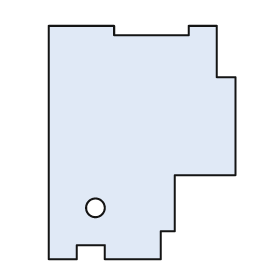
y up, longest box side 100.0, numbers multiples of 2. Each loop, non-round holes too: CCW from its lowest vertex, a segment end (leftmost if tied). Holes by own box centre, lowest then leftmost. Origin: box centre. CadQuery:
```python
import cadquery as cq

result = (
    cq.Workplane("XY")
    .moveTo(-40.0, -50.0)
    .lineTo(-28.0, -50.0)
    .lineTo(-28.0, -44.0)
    .lineTo(-16.0, -44.0)
    .lineTo(-16.0, -50.0)
    .lineTo(8.0, -50.0)
    .lineTo(8.0, -38.0)
    .lineTo(14.0, -38.0)
    .lineTo(14.0, -14.0)
    .lineTo(40.0, -14.0)
    .lineTo(40.0, 28.0)
    .lineTo(32.0, 28.0)
    .lineTo(32.0, 50.0)
    .lineTo(20.0, 50.0)
    .lineTo(20.0, 46.0)
    .lineTo(-12.0, 46.0)
    .lineTo(-12.0, 50.0)
    .lineTo(-40.0, 50.0)
    .close()
    .moveTo(-20.0, -28.0)
    .circle(4.0)
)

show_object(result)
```